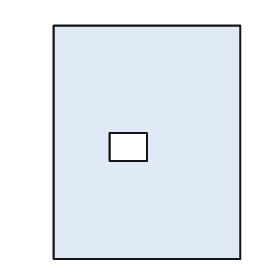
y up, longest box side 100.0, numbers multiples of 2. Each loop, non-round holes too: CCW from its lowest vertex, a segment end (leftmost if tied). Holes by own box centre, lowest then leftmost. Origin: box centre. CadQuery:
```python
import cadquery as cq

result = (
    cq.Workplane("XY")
    .moveTo(-40.0, -50.0)
    .lineTo(40.0, -50.0)
    .lineTo(40.0, 50.0)
    .lineTo(-40.0, 50.0)
    .close()
    .moveTo(-16.0, -8.0)
    .lineTo(0.0, -8.0)
    .lineTo(0.0, 4.0)
    .lineTo(-16.0, 4.0)
    .close()
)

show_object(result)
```